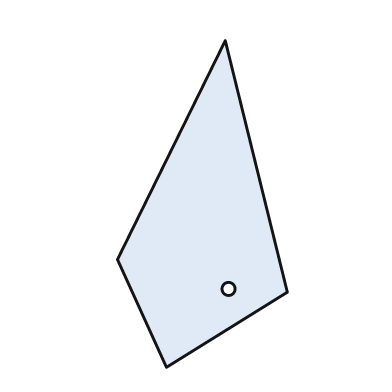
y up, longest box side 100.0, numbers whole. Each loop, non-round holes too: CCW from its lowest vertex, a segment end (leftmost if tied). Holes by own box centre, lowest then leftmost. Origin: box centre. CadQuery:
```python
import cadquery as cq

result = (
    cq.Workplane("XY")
    .moveTo(-11.0, -50.0)
    .lineTo(26.0, -27.0)
    .lineTo(7.0, 50.0)
    .lineTo(-26.0, -17.0)
    .close()
    .moveTo(8.0, -26.0)
    .circle(2.0)
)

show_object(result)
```